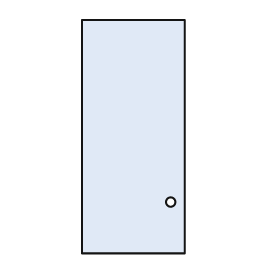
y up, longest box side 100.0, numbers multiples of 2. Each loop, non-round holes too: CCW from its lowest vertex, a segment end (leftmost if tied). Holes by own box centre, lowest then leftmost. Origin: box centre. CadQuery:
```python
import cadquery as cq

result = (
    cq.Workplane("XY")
    .moveTo(-22.0, -50.0)
    .lineTo(22.0, -50.0)
    .lineTo(22.0, 50.0)
    .lineTo(-22.0, 50.0)
    .close()
    .moveTo(16.0, -28.0)
    .circle(2.0)
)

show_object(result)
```